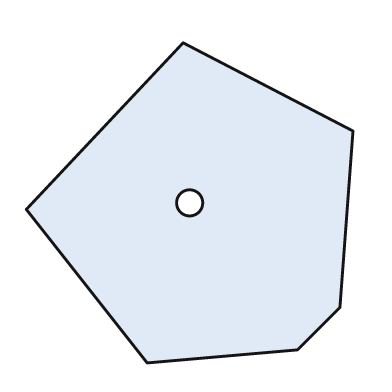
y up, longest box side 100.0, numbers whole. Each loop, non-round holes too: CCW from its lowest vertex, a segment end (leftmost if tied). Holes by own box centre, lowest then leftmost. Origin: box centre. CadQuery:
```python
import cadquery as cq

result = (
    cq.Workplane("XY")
    .moveTo(-13.0, -49.0)
    .lineTo(33.0, -45.0)
    .lineTo(46.0, -32.0)
    .lineTo(50.0, 22.0)
    .lineTo(-2.0, 49.0)
    .lineTo(-50.0, -2.0)
    .close()
    .moveTo(0.0, 0.0)
    .circle(4.0)
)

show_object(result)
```